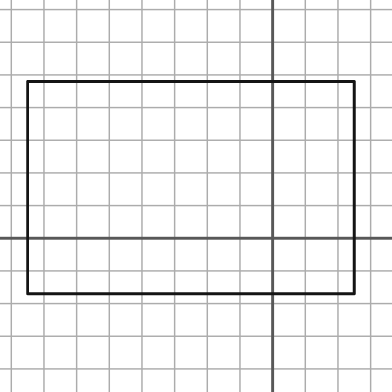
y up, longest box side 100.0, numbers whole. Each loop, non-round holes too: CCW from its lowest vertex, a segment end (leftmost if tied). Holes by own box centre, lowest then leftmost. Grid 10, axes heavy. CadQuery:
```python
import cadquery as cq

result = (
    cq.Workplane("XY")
    .moveTo(-75.0, -17.0)
    .lineTo(25.0, -17.0)
    .lineTo(25.0, 48.0)
    .lineTo(-75.0, 48.0)
    .close()
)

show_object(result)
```